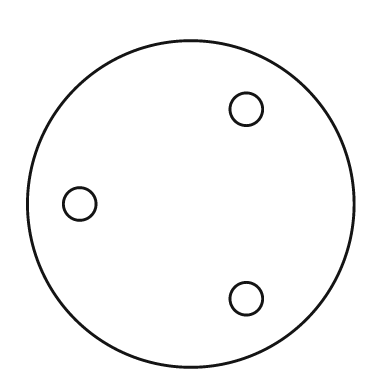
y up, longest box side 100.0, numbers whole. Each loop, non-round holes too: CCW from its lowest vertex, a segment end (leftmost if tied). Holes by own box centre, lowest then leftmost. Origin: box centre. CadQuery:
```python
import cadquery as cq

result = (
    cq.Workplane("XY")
    .moveTo(0.0, 0.0)
    .circle(50.0)
    .moveTo(17.0, -29.0)
    .circle(5.0)
    .moveTo(-34.0, 0.0)
    .circle(5.0)
    .moveTo(17.0, 29.0)
    .circle(5.0)
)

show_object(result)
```